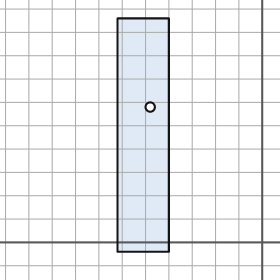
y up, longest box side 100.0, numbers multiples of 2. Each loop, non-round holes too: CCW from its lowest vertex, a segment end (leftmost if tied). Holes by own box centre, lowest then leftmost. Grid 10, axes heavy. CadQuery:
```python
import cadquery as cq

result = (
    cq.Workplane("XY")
    .moveTo(-62.0, -4.0)
    .lineTo(-40.0, -4.0)
    .lineTo(-40.0, 96.0)
    .lineTo(-62.0, 96.0)
    .close()
    .moveTo(-48.0, 58.0)
    .circle(2.0)
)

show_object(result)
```